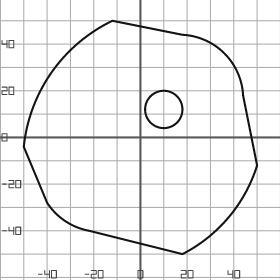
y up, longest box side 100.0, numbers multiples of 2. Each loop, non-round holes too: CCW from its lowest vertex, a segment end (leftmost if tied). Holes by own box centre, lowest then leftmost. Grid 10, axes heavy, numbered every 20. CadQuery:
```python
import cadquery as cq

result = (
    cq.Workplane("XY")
    .moveTo(18.0, -50.0)
    .threePointArc((38.0, -34.0), (50.0, -12.0))
    .lineTo(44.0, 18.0)
    .threePointArc((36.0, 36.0), (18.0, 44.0))
    .lineTo(-12.0, 50.0)
    .threePointArc((-38.0, 28.0), (-50.0, -4.0))
    .lineTo(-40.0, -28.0)
    .threePointArc((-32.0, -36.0), (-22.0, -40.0))
    .close()
    .moveTo(10.0, 12.0)
    .circle(8.0)
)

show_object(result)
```